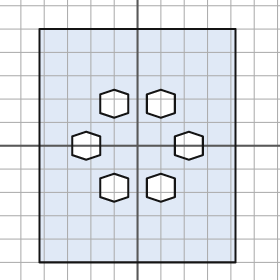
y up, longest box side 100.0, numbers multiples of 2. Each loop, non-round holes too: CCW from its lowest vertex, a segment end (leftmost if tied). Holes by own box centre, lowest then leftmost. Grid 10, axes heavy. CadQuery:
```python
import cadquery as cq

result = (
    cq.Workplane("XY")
    .moveTo(-42.0, -50.0)
    .lineTo(42.0, -50.0)
    .lineTo(42.0, 50.0)
    .lineTo(-42.0, 50.0)
    .close()
    .moveTo(-10.0, -24.0)
    .lineTo(-4.0, -22.0)
    .lineTo(-4.0, -14.0)
    .lineTo(-10.0, -12.0)
    .lineTo(-16.0, -14.0)
    .lineTo(-16.0, -22.0)
    .close()
    .moveTo(10.0, -24.0)
    .lineTo(16.0, -22.0)
    .lineTo(16.0, -14.0)
    .lineTo(10.0, -12.0)
    .lineTo(4.0, -14.0)
    .lineTo(4.0, -22.0)
    .close()
    .moveTo(-22.0, -6.0)
    .lineTo(-16.0, -4.0)
    .lineTo(-16.0, 4.0)
    .lineTo(-22.0, 6.0)
    .lineTo(-28.0, 4.0)
    .lineTo(-28.0, -4.0)
    .close()
    .moveTo(22.0, -6.0)
    .lineTo(28.0, -4.0)
    .lineTo(28.0, 4.0)
    .lineTo(22.0, 6.0)
    .lineTo(16.0, 4.0)
    .lineTo(16.0, -4.0)
    .close()
    .moveTo(-10.0, 12.0)
    .lineTo(-4.0, 14.0)
    .lineTo(-4.0, 22.0)
    .lineTo(-10.0, 24.0)
    .lineTo(-16.0, 22.0)
    .lineTo(-16.0, 14.0)
    .close()
    .moveTo(10.0, 12.0)
    .lineTo(16.0, 14.0)
    .lineTo(16.0, 22.0)
    .lineTo(10.0, 24.0)
    .lineTo(4.0, 22.0)
    .lineTo(4.0, 14.0)
    .close()
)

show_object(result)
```